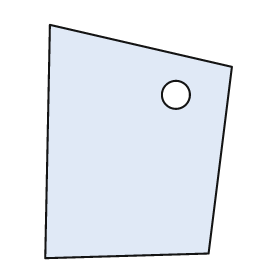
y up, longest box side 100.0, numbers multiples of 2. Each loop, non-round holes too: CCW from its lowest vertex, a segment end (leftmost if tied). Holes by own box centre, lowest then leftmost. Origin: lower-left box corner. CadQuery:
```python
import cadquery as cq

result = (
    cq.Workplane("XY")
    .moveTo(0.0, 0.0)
    .lineTo(70.0, 2.0)
    .lineTo(80.0, 82.0)
    .lineTo(2.0, 100.0)
    .close()
    .moveTo(56.0, 70.0)
    .circle(6.0)
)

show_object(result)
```